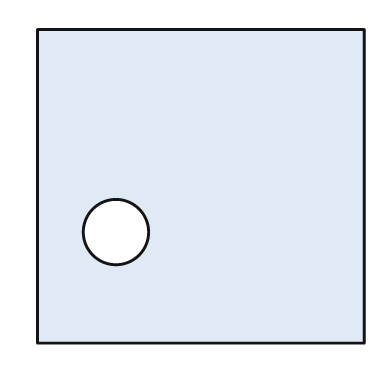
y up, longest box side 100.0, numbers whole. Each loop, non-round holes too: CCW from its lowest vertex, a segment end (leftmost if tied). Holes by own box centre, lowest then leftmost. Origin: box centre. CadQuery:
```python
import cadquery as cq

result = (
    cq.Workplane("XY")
    .moveTo(-50.0, -48.0)
    .lineTo(50.0, -48.0)
    .lineTo(50.0, 48.0)
    .lineTo(-50.0, 48.0)
    .close()
    .moveTo(-26.0, -14.0)
    .circle(10.0)
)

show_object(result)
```